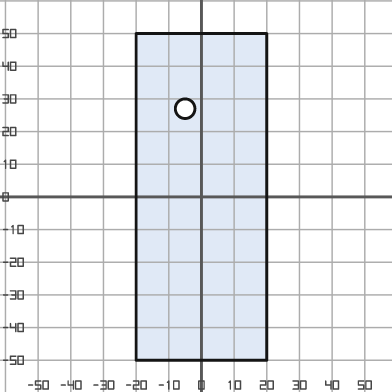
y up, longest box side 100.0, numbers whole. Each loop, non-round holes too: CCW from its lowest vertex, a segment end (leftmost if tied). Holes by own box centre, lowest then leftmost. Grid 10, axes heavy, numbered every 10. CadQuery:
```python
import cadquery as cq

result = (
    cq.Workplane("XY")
    .moveTo(-20.0, -50.0)
    .lineTo(20.0, -50.0)
    .lineTo(20.0, 50.0)
    .lineTo(-20.0, 50.0)
    .close()
    .moveTo(-5.0, 27.0)
    .circle(3.0)
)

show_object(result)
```